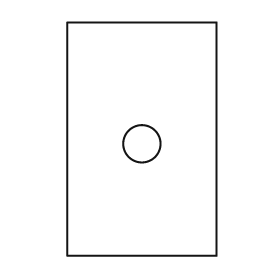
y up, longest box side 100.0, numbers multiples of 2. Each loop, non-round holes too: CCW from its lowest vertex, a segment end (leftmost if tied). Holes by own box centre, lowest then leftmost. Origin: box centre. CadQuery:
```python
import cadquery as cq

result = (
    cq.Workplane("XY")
    .moveTo(-32.0, -50.0)
    .lineTo(32.0, -50.0)
    .lineTo(32.0, 50.0)
    .lineTo(-32.0, 50.0)
    .close()
    .moveTo(0.0, -2.0)
    .circle(8.0)
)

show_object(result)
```